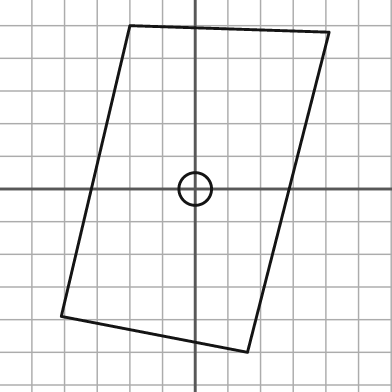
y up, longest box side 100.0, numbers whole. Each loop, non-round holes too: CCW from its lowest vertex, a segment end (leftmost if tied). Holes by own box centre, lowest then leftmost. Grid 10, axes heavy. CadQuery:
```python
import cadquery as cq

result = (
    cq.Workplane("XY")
    .moveTo(16.0, -50.0)
    .lineTo(41.0, 48.0)
    .lineTo(-20.0, 50.0)
    .lineTo(-41.0, -39.0)
    .close()
    .moveTo(0.0, 0.0)
    .circle(5.0)
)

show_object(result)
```